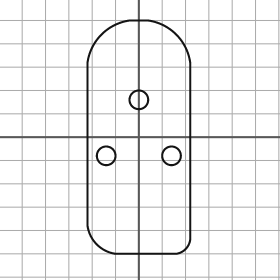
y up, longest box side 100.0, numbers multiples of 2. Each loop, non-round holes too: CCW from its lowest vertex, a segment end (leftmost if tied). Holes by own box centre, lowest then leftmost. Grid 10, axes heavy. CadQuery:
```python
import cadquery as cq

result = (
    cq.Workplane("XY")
    .moveTo(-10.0, -50.0)
    .lineTo(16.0, -50.0)
    .threePointArc((20.0, -48.0), (22.0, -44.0))
    .lineTo(22.0, 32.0)
    .threePointArc((16.0, 44.0), (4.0, 50.0))
    .lineTo(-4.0, 50.0)
    .threePointArc((-16.0, 44.0), (-22.0, 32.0))
    .lineTo(-22.0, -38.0)
    .threePointArc((-18.0, -46.0), (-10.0, -50.0))
    .close()
    .moveTo(-14.0, -8.0)
    .circle(4.0)
    .moveTo(14.0, -8.0)
    .circle(4.0)
    .moveTo(0.0, 16.0)
    .circle(4.0)
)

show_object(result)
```